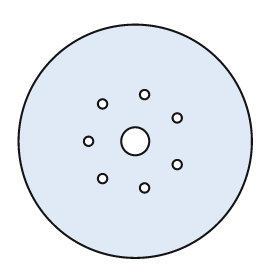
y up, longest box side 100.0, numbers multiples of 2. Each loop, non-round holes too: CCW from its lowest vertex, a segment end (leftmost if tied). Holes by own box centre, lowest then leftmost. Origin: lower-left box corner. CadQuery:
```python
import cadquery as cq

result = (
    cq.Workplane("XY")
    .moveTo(50.0, 50.0)
    .circle(50.0)
    .moveTo(54.0, 30.0)
    .circle(2.0)
    .moveTo(36.0, 34.0)
    .circle(2.0)
    .moveTo(68.0, 40.0)
    .circle(2.0)
    .moveTo(30.0, 50.0)
    .circle(2.0)
    .moveTo(50.0, 50.0)
    .circle(6.0)
    .moveTo(68.0, 60.0)
    .circle(2.0)
    .moveTo(36.0, 66.0)
    .circle(2.0)
    .moveTo(54.0, 70.0)
    .circle(2.0)
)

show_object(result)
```